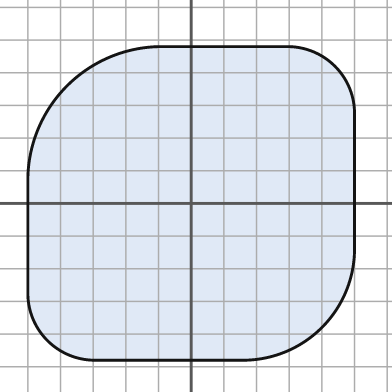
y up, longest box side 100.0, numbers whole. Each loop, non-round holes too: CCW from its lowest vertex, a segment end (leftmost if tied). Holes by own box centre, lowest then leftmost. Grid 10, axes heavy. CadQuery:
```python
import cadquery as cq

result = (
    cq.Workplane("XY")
    .moveTo(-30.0, -48.0)
    .lineTo(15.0, -48.0)
    .threePointArc((40.0, -38.0), (50.0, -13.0))
    .lineTo(50.0, 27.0)
    .threePointArc((44.0, 42.0), (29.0, 48.0))
    .lineTo(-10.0, 48.0)
    .threePointArc((-38.0, 36.0), (-50.0, 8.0))
    .lineTo(-50.0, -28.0)
    .threePointArc((-44.0, -42.0), (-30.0, -48.0))
    .close()
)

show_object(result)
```